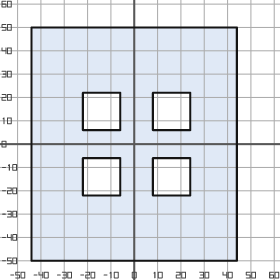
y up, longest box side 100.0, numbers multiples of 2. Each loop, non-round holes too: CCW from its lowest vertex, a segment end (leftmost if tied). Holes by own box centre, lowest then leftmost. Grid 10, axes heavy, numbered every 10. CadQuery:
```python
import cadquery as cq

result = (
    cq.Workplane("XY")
    .moveTo(-44.0, -50.0)
    .lineTo(44.0, -50.0)
    .lineTo(44.0, 50.0)
    .lineTo(-44.0, 50.0)
    .close()
    .moveTo(-22.0, -22.0)
    .lineTo(-6.0, -22.0)
    .lineTo(-6.0, -6.0)
    .lineTo(-22.0, -6.0)
    .close()
    .moveTo(8.0, -22.0)
    .lineTo(24.0, -22.0)
    .lineTo(24.0, -6.0)
    .lineTo(8.0, -6.0)
    .close()
    .moveTo(-22.0, 6.0)
    .lineTo(-6.0, 6.0)
    .lineTo(-6.0, 22.0)
    .lineTo(-22.0, 22.0)
    .close()
    .moveTo(8.0, 6.0)
    .lineTo(24.0, 6.0)
    .lineTo(24.0, 22.0)
    .lineTo(8.0, 22.0)
    .close()
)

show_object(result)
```